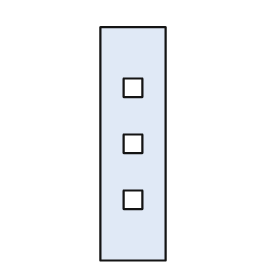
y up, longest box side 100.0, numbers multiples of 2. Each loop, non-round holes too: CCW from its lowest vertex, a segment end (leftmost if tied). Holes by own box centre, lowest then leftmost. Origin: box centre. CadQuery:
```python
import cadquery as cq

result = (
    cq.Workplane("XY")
    .moveTo(-14.0, -50.0)
    .lineTo(14.0, -50.0)
    .lineTo(14.0, 50.0)
    .lineTo(-14.0, 50.0)
    .close()
    .moveTo(-4.0, -28.0)
    .lineTo(4.0, -28.0)
    .lineTo(4.0, -20.0)
    .lineTo(-4.0, -20.0)
    .close()
    .moveTo(-4.0, -4.0)
    .lineTo(4.0, -4.0)
    .lineTo(4.0, 4.0)
    .lineTo(-4.0, 4.0)
    .close()
    .moveTo(-4.0, 20.0)
    .lineTo(4.0, 20.0)
    .lineTo(4.0, 28.0)
    .lineTo(-4.0, 28.0)
    .close()
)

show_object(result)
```